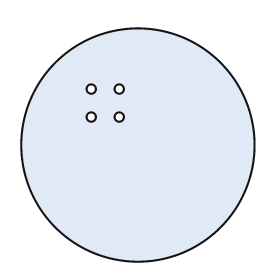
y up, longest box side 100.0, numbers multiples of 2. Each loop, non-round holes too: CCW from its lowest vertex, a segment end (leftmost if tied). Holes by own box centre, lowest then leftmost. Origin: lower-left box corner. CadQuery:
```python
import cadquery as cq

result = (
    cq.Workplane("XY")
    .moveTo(50.0, 50.0)
    .circle(50.0)
    .moveTo(30.0, 62.0)
    .circle(2.0)
    .moveTo(42.0, 62.0)
    .circle(2.0)
    .moveTo(30.0, 74.0)
    .circle(2.0)
    .moveTo(42.0, 74.0)
    .circle(2.0)
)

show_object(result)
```